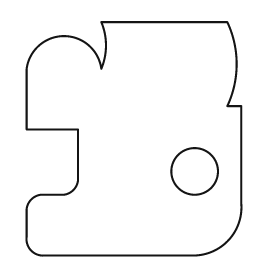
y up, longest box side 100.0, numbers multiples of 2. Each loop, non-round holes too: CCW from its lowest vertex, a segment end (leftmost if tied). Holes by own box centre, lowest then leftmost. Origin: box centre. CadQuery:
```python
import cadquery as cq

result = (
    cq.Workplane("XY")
    .moveTo(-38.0, -50.0)
    .lineTo(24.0, -50.0)
    .threePointArc((40.0, -44.0), (46.0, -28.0))
    .lineTo(46.0, 14.0)
    .lineTo(40.0, 14.0)
    .threePointArc((44.0, 32.0), (40.0, 50.0))
    .lineTo(-14.0, 50.0)
    .threePointArc((-12.0, 40.0), (-14.0, 30.0))
    .threePointArc((-30.0, 44.0), (-46.0, 30.0))
    .lineTo(-46.0, 4.0)
    .lineTo(-24.0, 4.0)
    .lineTo(-24.0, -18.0)
    .threePointArc((-26.0, -22.0), (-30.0, -24.0))
    .lineTo(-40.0, -24.0)
    .threePointArc((-44.0, -26.0), (-46.0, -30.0))
    .lineTo(-46.0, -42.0)
    .threePointArc((-44.0, -48.0), (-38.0, -50.0))
    .close()
    .moveTo(26.0, -14.0)
    .circle(10.0)
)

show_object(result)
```